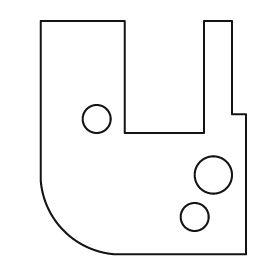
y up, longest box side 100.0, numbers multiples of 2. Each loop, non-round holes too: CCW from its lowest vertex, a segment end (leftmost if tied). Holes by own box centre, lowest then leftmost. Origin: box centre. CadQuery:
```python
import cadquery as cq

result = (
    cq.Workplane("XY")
    .moveTo(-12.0, -50.0)
    .lineTo(44.0, -50.0)
    .lineTo(44.0, 10.0)
    .lineTo(38.0, 10.0)
    .lineTo(38.0, 50.0)
    .lineTo(26.0, 50.0)
    .lineTo(26.0, 2.0)
    .lineTo(-8.0, 2.0)
    .lineTo(-8.0, 50.0)
    .lineTo(-44.0, 50.0)
    .lineTo(-44.0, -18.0)
    .threePointArc((-34.0, -40.0), (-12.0, -50.0))
    .close()
    .moveTo(22.0, -34.0)
    .circle(6.0)
    .moveTo(30.0, -16.0)
    .circle(8.0)
    .moveTo(-20.0, 8.0)
    .circle(6.0)
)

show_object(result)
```